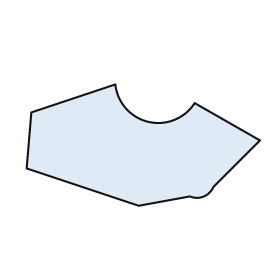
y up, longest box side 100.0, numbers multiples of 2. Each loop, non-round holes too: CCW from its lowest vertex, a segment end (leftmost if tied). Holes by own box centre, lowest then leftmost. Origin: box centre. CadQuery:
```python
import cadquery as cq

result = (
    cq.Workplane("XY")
    .moveTo(-2.0, -26.0)
    .lineTo(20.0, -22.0)
    .threePointArc((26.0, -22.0), (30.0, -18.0))
    .lineTo(50.0, 2.0)
    .lineTo(22.0, 18.0)
    .threePointArc((2.0, 10.0), (-12.0, 26.0))
    .lineTo(-48.0, 14.0)
    .lineTo(-50.0, -10.0)
    .close()
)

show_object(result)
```